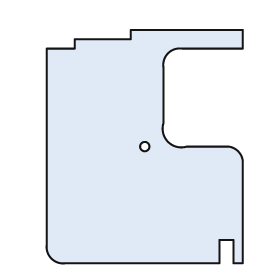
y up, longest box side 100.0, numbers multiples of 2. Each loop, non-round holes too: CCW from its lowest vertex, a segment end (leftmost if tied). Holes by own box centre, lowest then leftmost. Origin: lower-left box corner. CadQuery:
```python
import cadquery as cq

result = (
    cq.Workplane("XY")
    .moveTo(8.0, 0.0)
    .lineTo(74.0, 0.0)
    .lineTo(74.0, 10.0)
    .lineTo(80.0, 10.0)
    .lineTo(80.0, 0.0)
    .lineTo(84.0, 0.0)
    .lineTo(84.0, 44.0)
    .threePointArc((82.0, 48.0), (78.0, 50.0))
    .lineTo(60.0, 50.0)
    .threePointArc((52.0, 52.0), (50.0, 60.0))
    .lineTo(50.0, 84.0)
    .threePointArc((52.0, 90.0), (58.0, 92.0))
    .lineTo(84.0, 92.0)
    .lineTo(84.0, 100.0)
    .lineTo(36.0, 100.0)
    .lineTo(36.0, 96.0)
    .lineTo(12.0, 96.0)
    .lineTo(12.0, 92.0)
    .lineTo(0.0, 92.0)
    .lineTo(0.0, 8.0)
    .threePointArc((2.0, 2.0), (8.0, 0.0))
    .close()
    .moveTo(42.0, 50.0)
    .circle(2.0)
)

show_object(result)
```